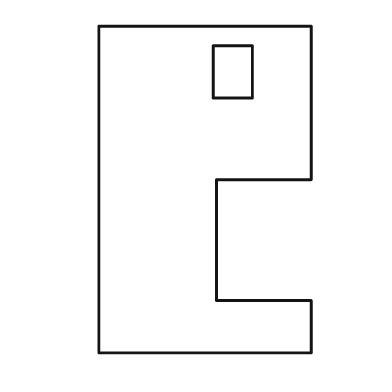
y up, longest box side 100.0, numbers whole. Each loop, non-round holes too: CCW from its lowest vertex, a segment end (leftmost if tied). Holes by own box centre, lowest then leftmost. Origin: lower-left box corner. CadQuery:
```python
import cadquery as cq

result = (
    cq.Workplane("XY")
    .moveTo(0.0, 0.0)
    .lineTo(65.0, 0.0)
    .lineTo(65.0, 16.0)
    .lineTo(36.0, 16.0)
    .lineTo(36.0, 53.0)
    .lineTo(65.0, 53.0)
    .lineTo(65.0, 100.0)
    .lineTo(0.0, 100.0)
    .close()
    .moveTo(35.0, 78.0)
    .lineTo(47.0, 78.0)
    .lineTo(47.0, 94.0)
    .lineTo(35.0, 94.0)
    .close()
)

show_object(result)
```